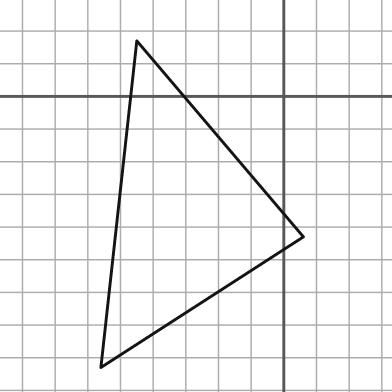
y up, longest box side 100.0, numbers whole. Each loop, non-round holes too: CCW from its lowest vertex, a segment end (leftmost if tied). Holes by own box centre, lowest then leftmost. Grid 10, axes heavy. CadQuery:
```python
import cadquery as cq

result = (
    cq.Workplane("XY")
    .moveTo(-56.0, -83.0)
    .lineTo(6.0, -43.0)
    .lineTo(-45.0, 17.0)
    .close()
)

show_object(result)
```